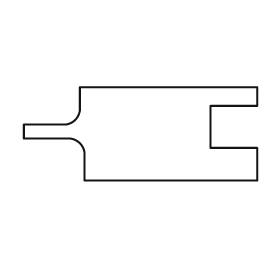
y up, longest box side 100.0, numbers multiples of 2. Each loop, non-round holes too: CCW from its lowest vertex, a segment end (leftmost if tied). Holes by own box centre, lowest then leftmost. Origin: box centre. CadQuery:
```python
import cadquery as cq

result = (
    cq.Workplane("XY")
    .moveTo(-24.0, -20.0)
    .lineTo(50.0, -20.0)
    .lineTo(50.0, -6.0)
    .lineTo(30.0, -6.0)
    .lineTo(30.0, 12.0)
    .lineTo(50.0, 12.0)
    .lineTo(50.0, 20.0)
    .lineTo(-26.0, 20.0)
    .lineTo(-26.0, 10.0)
    .threePointArc((-28.0, 6.0), (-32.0, 4.0))
    .lineTo(-50.0, 4.0)
    .lineTo(-50.0, -2.0)
    .lineTo(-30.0, -2.0)
    .threePointArc((-26.0, -4.0), (-24.0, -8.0))
    .close()
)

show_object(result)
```